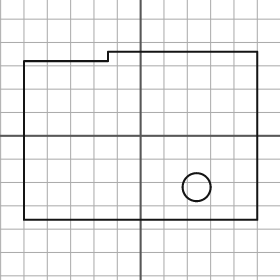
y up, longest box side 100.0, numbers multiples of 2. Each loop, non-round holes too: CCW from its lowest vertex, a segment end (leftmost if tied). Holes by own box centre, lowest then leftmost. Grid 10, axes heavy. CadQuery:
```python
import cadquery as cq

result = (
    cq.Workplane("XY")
    .moveTo(-50.0, -36.0)
    .lineTo(50.0, -36.0)
    .lineTo(50.0, 36.0)
    .lineTo(-14.0, 36.0)
    .lineTo(-14.0, 32.0)
    .lineTo(-50.0, 32.0)
    .close()
    .moveTo(24.0, -22.0)
    .circle(6.0)
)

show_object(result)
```